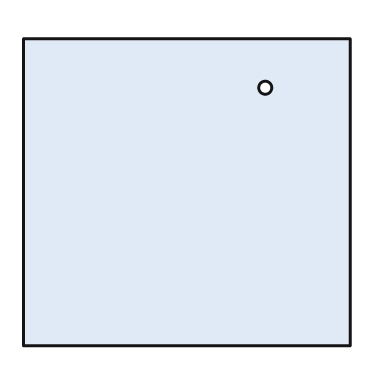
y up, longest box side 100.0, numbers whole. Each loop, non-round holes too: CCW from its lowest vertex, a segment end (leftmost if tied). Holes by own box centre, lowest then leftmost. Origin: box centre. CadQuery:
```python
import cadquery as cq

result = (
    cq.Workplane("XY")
    .moveTo(-50.0, -47.0)
    .lineTo(50.0, -47.0)
    .lineTo(50.0, 47.0)
    .lineTo(-50.0, 47.0)
    .close()
    .moveTo(24.0, 32.0)
    .circle(2.0)
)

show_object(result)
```